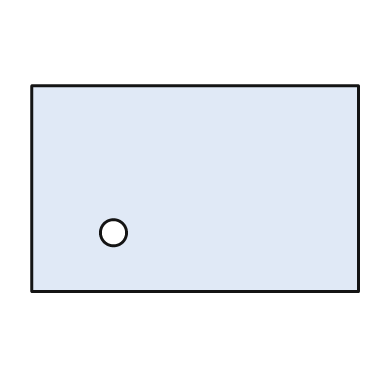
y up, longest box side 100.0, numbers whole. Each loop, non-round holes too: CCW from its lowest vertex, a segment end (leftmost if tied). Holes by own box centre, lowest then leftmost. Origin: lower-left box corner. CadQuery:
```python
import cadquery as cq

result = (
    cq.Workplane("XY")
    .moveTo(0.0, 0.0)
    .lineTo(100.0, 0.0)
    .lineTo(100.0, 63.0)
    .lineTo(0.0, 63.0)
    .close()
    .moveTo(25.0, 18.0)
    .circle(4.0)
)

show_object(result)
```